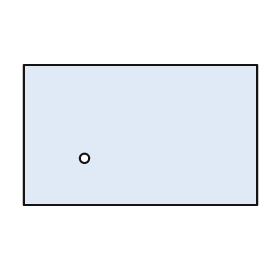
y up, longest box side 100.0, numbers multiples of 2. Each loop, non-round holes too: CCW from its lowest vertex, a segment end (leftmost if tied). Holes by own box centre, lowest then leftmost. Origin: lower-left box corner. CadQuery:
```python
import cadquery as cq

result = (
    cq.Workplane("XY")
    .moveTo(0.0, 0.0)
    .lineTo(100.0, 0.0)
    .lineTo(100.0, 60.0)
    .lineTo(0.0, 60.0)
    .close()
    .moveTo(26.0, 20.0)
    .circle(2.0)
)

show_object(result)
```